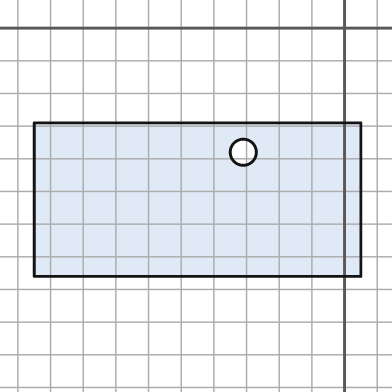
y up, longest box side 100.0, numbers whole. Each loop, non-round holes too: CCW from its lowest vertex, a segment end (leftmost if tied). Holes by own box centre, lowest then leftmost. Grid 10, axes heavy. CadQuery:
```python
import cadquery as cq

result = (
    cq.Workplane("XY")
    .moveTo(-95.0, -76.0)
    .lineTo(5.0, -76.0)
    .lineTo(5.0, -29.0)
    .lineTo(-95.0, -29.0)
    .close()
    .moveTo(-31.0, -38.0)
    .circle(4.0)
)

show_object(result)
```